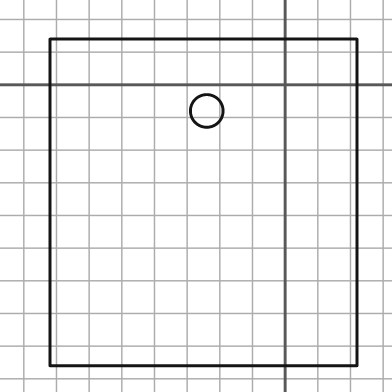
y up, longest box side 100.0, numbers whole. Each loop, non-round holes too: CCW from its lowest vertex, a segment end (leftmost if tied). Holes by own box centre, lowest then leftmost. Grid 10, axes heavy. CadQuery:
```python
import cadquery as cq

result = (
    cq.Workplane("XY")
    .moveTo(-72.0, -86.0)
    .lineTo(22.0, -86.0)
    .lineTo(22.0, 14.0)
    .lineTo(-72.0, 14.0)
    .close()
    .moveTo(-24.0, -8.0)
    .circle(5.0)
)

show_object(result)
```